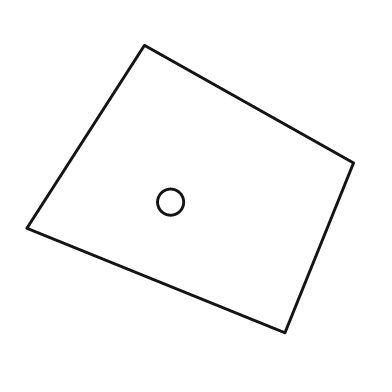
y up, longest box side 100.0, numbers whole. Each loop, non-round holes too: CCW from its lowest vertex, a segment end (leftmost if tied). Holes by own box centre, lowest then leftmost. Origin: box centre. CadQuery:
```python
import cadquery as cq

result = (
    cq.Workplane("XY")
    .moveTo(29.0, -44.0)
    .lineTo(50.0, 8.0)
    .lineTo(-14.0, 44.0)
    .lineTo(-50.0, -12.0)
    .close()
    .moveTo(-6.0, -4.0)
    .circle(4.0)
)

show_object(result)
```